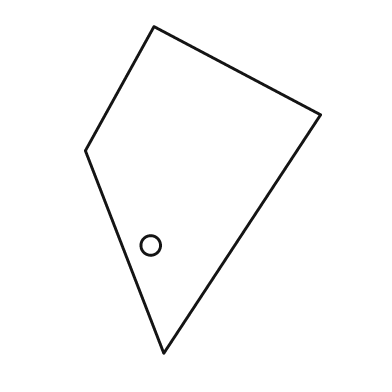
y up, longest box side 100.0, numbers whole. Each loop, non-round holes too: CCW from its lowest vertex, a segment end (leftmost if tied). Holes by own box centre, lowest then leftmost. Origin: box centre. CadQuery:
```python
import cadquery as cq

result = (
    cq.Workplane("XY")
    .moveTo(-12.0, -50.0)
    .lineTo(36.0, 23.0)
    .lineTo(-15.0, 50.0)
    .lineTo(-36.0, 12.0)
    .close()
    .moveTo(-16.0, -17.0)
    .circle(3.0)
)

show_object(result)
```